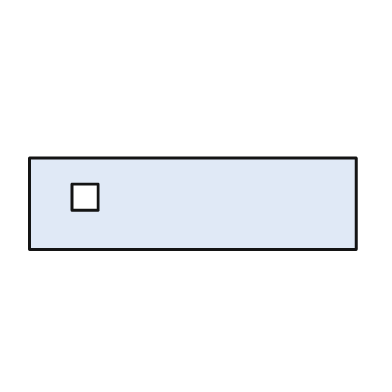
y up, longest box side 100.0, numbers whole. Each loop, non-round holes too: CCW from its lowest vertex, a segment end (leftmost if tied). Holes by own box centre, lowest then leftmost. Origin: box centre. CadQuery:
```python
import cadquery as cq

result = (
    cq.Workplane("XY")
    .moveTo(-50.0, -14.0)
    .lineTo(50.0, -14.0)
    .lineTo(50.0, 14.0)
    .lineTo(-50.0, 14.0)
    .close()
    .moveTo(-37.0, -2.0)
    .lineTo(-29.0, -2.0)
    .lineTo(-29.0, 6.0)
    .lineTo(-37.0, 6.0)
    .close()
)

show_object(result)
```